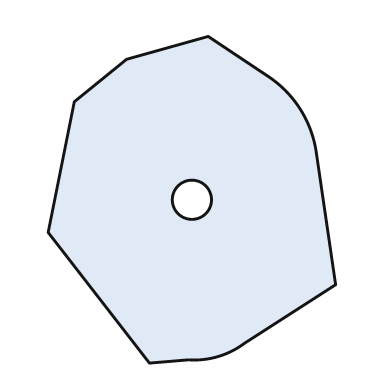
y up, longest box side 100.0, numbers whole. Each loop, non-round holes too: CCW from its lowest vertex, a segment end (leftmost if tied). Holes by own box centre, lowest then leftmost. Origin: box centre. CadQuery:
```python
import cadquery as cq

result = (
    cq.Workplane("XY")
    .moveTo(-13.0, -50.0)
    .lineTo(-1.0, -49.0)
    .threePointArc((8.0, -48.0), (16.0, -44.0))
    .lineTo(44.0, -26.0)
    .lineTo(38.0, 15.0)
    .threePointArc((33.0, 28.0), (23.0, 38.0))
    .lineTo(5.0, 50.0)
    .lineTo(-20.0, 43.0)
    .lineTo(-36.0, 30.0)
    .lineTo(-44.0, -10.0)
    .close()
    .moveTo(0.0, 0.0)
    .circle(6.0)
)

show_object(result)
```